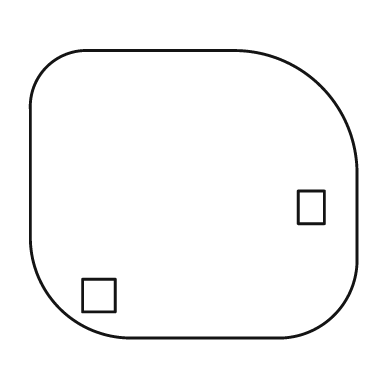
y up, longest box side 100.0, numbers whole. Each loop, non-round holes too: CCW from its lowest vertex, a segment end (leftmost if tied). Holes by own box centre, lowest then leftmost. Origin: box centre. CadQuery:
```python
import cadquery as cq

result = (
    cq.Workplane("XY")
    .moveTo(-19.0, -44.0)
    .lineTo(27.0, -44.0)
    .threePointArc((43.0, -37.0), (50.0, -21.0))
    .lineTo(50.0, 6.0)
    .threePointArc((39.0, 33.0), (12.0, 44.0))
    .lineTo(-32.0, 44.0)
    .threePointArc((-45.0, 39.0), (-50.0, 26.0))
    .lineTo(-50.0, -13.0)
    .threePointArc((-41.0, -35.0), (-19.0, -44.0))
    .close()
    .moveTo(-34.0, -36.0)
    .lineTo(-24.0, -36.0)
    .lineTo(-24.0, -26.0)
    .lineTo(-34.0, -26.0)
    .close()
    .moveTo(32.0, -9.0)
    .lineTo(40.0, -9.0)
    .lineTo(40.0, 1.0)
    .lineTo(32.0, 1.0)
    .close()
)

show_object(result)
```